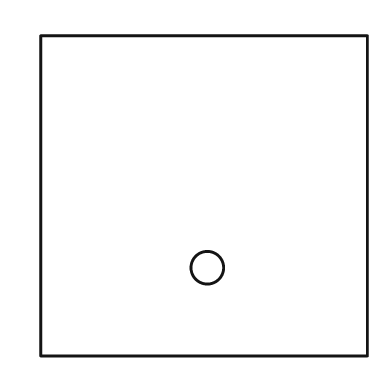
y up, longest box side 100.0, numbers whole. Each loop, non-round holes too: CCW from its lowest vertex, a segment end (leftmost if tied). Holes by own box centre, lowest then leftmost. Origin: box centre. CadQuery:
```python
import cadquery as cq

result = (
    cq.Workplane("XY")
    .moveTo(-50.0, -49.0)
    .lineTo(50.0, -49.0)
    .lineTo(50.0, 49.0)
    .lineTo(-50.0, 49.0)
    .close()
    .moveTo(1.0, -22.0)
    .circle(5.0)
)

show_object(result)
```